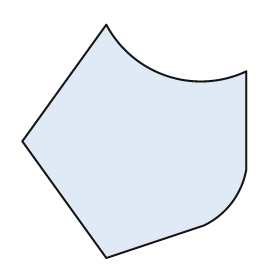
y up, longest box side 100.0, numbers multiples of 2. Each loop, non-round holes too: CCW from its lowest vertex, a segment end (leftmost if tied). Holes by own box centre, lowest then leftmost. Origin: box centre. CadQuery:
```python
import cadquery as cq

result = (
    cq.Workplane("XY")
    .moveTo(-12.0, -50.0)
    .lineTo(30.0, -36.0)
    .threePointArc((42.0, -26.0), (48.0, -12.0))
    .lineTo(48.0, 30.0)
    .threePointArc((14.0, 28.0), (-12.0, 50.0))
    .lineTo(-48.0, 0.0)
    .close()
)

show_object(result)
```